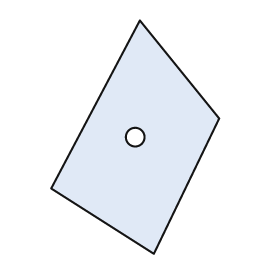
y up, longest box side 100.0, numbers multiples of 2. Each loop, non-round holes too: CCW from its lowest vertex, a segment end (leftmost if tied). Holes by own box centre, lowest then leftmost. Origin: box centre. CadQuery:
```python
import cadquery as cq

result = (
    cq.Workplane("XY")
    .moveTo(8.0, -50.0)
    .lineTo(36.0, 8.0)
    .lineTo(2.0, 50.0)
    .lineTo(-36.0, -22.0)
    .close()
    .moveTo(0.0, 0.0)
    .circle(4.0)
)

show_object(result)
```